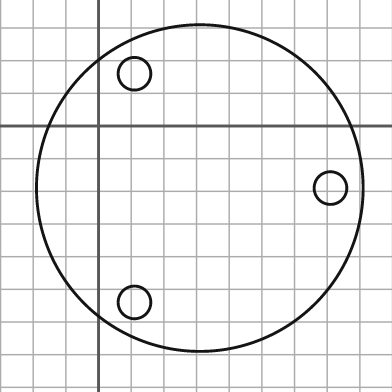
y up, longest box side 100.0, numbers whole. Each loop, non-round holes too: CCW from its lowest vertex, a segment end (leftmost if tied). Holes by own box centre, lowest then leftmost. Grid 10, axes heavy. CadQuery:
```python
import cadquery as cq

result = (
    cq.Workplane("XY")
    .moveTo(31.0, -19.0)
    .circle(50.0)
    .moveTo(11.0, -54.0)
    .circle(5.0)
    .moveTo(71.0, -19.0)
    .circle(5.0)
    .moveTo(11.0, 16.0)
    .circle(5.0)
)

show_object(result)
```